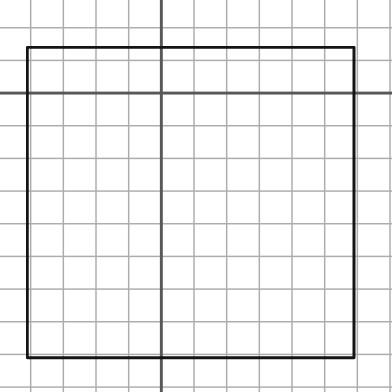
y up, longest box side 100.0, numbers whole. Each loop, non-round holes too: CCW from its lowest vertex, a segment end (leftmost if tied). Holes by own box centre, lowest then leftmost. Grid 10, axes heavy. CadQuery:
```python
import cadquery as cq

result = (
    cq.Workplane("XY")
    .moveTo(-41.0, -81.0)
    .lineTo(59.0, -81.0)
    .lineTo(59.0, 14.0)
    .lineTo(-41.0, 14.0)
    .close()
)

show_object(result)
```